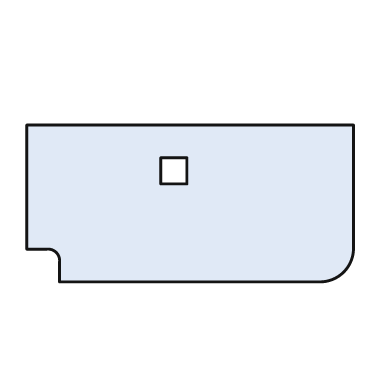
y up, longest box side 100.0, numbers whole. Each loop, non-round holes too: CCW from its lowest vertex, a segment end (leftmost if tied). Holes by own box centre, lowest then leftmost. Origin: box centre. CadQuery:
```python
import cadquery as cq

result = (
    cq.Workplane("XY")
    .moveTo(-40.0, -24.0)
    .lineTo(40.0, -24.0)
    .threePointArc((47.0, -21.0), (50.0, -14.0))
    .lineTo(50.0, 24.0)
    .lineTo(-50.0, 24.0)
    .lineTo(-50.0, -14.0)
    .lineTo(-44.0, -14.0)
    .threePointArc((-41.0, -15.0), (-40.0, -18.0))
    .close()
    .moveTo(-9.0, 6.0)
    .lineTo(-1.0, 6.0)
    .lineTo(-1.0, 14.0)
    .lineTo(-9.0, 14.0)
    .close()
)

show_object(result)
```